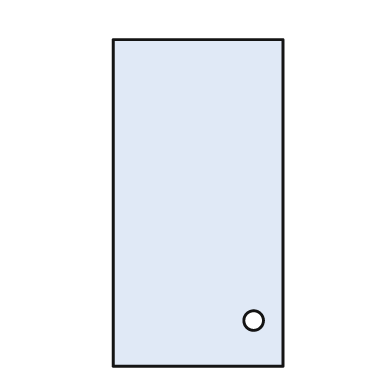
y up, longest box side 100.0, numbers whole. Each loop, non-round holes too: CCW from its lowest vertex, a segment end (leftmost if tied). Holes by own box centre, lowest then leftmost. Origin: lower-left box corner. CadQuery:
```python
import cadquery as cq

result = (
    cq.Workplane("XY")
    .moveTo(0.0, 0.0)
    .lineTo(52.0, 0.0)
    .lineTo(52.0, 100.0)
    .lineTo(0.0, 100.0)
    .close()
    .moveTo(43.0, 14.0)
    .circle(3.0)
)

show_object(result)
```